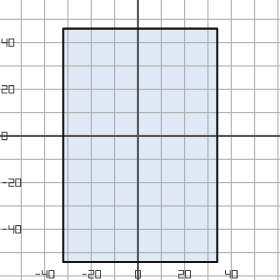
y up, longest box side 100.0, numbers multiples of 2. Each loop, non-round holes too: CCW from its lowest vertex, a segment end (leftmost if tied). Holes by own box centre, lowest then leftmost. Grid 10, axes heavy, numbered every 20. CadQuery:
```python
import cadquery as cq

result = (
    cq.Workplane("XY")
    .moveTo(-32.0, -54.0)
    .lineTo(34.0, -54.0)
    .lineTo(34.0, 46.0)
    .lineTo(-32.0, 46.0)
    .close()
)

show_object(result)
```